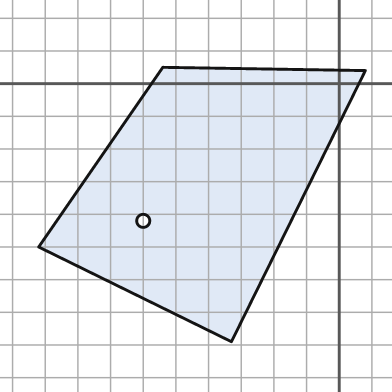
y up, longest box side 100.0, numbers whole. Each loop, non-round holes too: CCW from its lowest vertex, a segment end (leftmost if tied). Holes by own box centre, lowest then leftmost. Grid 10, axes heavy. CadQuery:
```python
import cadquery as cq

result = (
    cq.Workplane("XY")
    .moveTo(-33.0, -79.0)
    .lineTo(8.0, 4.0)
    .lineTo(-54.0, 5.0)
    .lineTo(-92.0, -50.0)
    .close()
    .moveTo(-60.0, -42.0)
    .circle(2.0)
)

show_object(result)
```